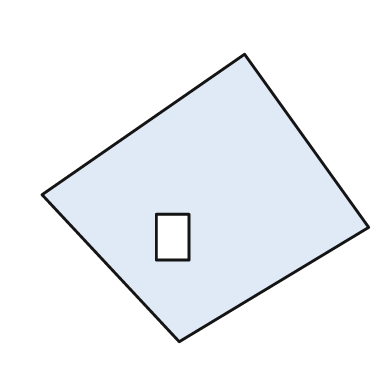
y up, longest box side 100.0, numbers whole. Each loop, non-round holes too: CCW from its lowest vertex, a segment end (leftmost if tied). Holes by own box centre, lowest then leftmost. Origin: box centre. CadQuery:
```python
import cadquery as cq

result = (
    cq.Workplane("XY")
    .moveTo(-8.0, -44.0)
    .lineTo(50.0, -9.0)
    .lineTo(12.0, 44.0)
    .lineTo(-50.0, 1.0)
    .close()
    .moveTo(-15.0, -19.0)
    .lineTo(-5.0, -19.0)
    .lineTo(-5.0, -5.0)
    .lineTo(-15.0, -5.0)
    .close()
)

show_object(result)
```